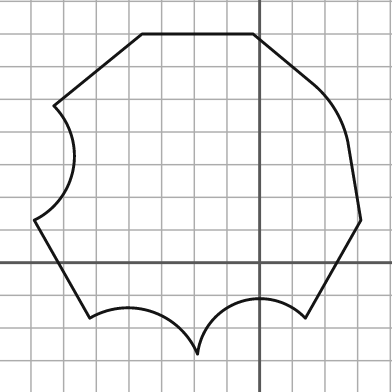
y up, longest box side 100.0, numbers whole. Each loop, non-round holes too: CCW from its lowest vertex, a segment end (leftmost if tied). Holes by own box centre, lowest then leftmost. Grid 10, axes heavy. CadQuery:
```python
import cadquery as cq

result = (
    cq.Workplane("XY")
    .moveTo(-19.0, -28.0)
    .threePointArc((-6.0, -12.0), (14.0, -17.0))
    .lineTo(31.0, 13.0)
    .lineTo(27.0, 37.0)
    .threePointArc((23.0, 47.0), (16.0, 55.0))
    .lineTo(-2.0, 70.0)
    .lineTo(-36.0, 70.0)
    .lineTo(-63.0, 48.0)
    .threePointArc((-57.0, 29.0), (-69.0, 13.0))
    .lineTo(-52.0, -17.0)
    .threePointArc((-33.0, -15.0), (-19.0, -28.0))
    .close()
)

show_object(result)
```